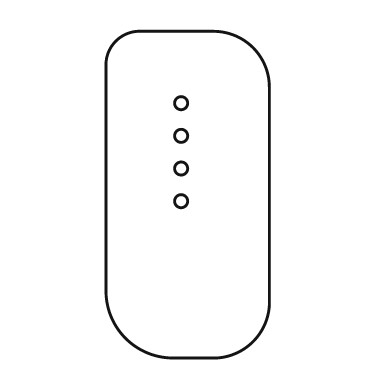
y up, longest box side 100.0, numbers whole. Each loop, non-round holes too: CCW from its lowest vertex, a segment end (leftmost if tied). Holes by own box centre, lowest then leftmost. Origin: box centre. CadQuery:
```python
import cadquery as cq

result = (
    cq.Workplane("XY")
    .moveTo(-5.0, -50.0)
    .lineTo(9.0, -50.0)
    .threePointArc((20.0, -45.0), (25.0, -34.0))
    .lineTo(25.0, 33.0)
    .threePointArc((20.0, 45.0), (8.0, 50.0))
    .lineTo(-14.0, 50.0)
    .threePointArc((-22.0, 47.0), (-25.0, 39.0))
    .lineTo(-25.0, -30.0)
    .threePointArc((-19.0, -44.0), (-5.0, -50.0))
    .close()
    .moveTo(-2.0, -2.0)
    .circle(2.0)
    .moveTo(-2.0, 8.0)
    .circle(2.0)
    .moveTo(-2.0, 18.0)
    .circle(2.0)
    .moveTo(-2.0, 28.0)
    .circle(2.0)
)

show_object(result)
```